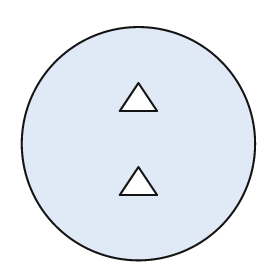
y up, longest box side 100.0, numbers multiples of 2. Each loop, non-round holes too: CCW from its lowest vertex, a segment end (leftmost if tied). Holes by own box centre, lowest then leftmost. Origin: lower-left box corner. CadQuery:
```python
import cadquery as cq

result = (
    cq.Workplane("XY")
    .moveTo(50.0, 50.0)
    .circle(50.0)
    .moveTo(42.0, 28.0)
    .lineTo(58.0, 28.0)
    .lineTo(50.0, 40.0)
    .close()
    .moveTo(42.0, 64.0)
    .lineTo(58.0, 64.0)
    .lineTo(50.0, 76.0)
    .close()
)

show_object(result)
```